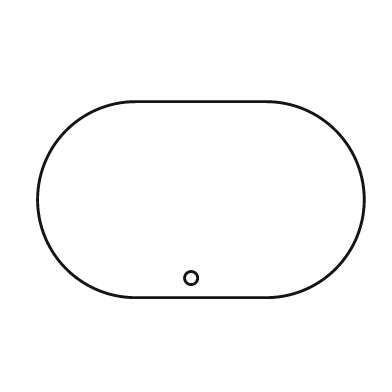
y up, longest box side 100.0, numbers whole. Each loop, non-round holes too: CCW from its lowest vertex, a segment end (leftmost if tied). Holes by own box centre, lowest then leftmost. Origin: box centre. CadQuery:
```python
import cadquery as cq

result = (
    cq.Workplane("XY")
    .moveTo(-20.0, -30.0)
    .lineTo(20.0, -30.0)
    .threePointArc((50.0, 0.0), (20.0, 30.0))
    .lineTo(-20.0, 30.0)
    .threePointArc((-50.0, 0.0), (-20.0, -30.0))
    .close()
    .moveTo(-3.0, -24.0)
    .circle(2.0)
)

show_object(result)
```